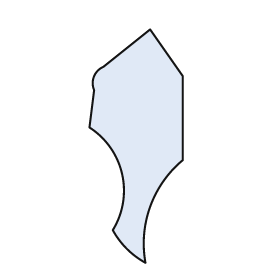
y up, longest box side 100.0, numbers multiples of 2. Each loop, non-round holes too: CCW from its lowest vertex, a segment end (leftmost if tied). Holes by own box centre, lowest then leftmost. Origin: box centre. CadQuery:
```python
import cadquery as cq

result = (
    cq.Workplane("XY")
    .moveTo(4.0, -50.0)
    .threePointArc((6.0, -26.0), (20.0, -6.0))
    .lineTo(20.0, 30.0)
    .lineTo(6.0, 50.0)
    .lineTo(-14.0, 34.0)
    .threePointArc((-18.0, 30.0), (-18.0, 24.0))
    .lineTo(-20.0, 8.0)
    .threePointArc((-6.0, -12.0), (-10.0, -36.0))
    .threePointArc((-4.0, -44.0), (4.0, -50.0))
    .close()
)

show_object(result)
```